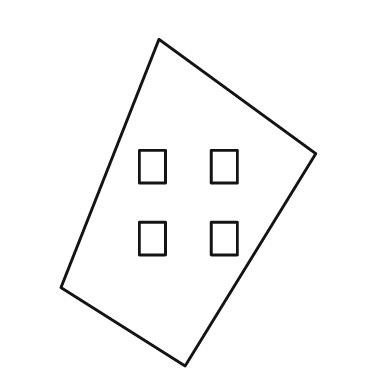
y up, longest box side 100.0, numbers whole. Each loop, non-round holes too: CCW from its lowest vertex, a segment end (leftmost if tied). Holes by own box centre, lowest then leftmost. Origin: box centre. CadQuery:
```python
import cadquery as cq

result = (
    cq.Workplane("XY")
    .moveTo(-1.0, -50.0)
    .lineTo(39.0, 15.0)
    .lineTo(-9.0, 50.0)
    .lineTo(-39.0, -26.0)
    .close()
    .moveTo(-15.0, -16.0)
    .lineTo(-7.0, -16.0)
    .lineTo(-7.0, -6.0)
    .lineTo(-15.0, -6.0)
    .close()
    .moveTo(7.0, -16.0)
    .lineTo(15.0, -16.0)
    .lineTo(15.0, -6.0)
    .lineTo(7.0, -6.0)
    .close()
    .moveTo(-15.0, 6.0)
    .lineTo(-7.0, 6.0)
    .lineTo(-7.0, 16.0)
    .lineTo(-15.0, 16.0)
    .close()
    .moveTo(7.0, 6.0)
    .lineTo(15.0, 6.0)
    .lineTo(15.0, 16.0)
    .lineTo(7.0, 16.0)
    .close()
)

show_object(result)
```